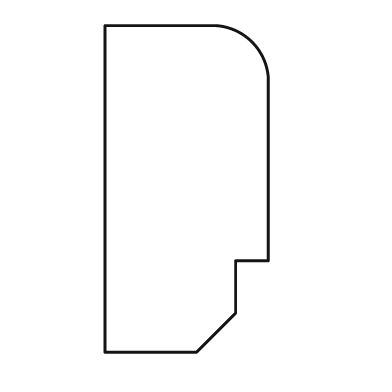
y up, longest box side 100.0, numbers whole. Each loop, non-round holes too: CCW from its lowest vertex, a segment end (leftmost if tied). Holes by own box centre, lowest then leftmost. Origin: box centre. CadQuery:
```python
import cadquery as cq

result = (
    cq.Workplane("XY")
    .moveTo(-25.0, -50.0)
    .lineTo(3.0, -50.0)
    .lineTo(15.0, -38.0)
    .lineTo(15.0, -22.0)
    .lineTo(25.0, -22.0)
    .lineTo(25.0, 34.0)
    .threePointArc((20.0, 45.0), (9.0, 50.0))
    .lineTo(-25.0, 50.0)
    .close()
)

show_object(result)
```